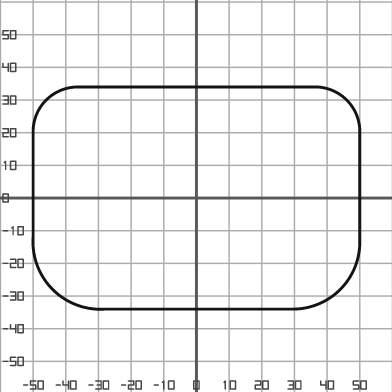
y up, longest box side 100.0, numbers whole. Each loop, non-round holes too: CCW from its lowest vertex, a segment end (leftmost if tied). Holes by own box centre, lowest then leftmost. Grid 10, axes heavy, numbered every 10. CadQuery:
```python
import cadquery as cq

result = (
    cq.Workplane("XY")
    .moveTo(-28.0, -34.0)
    .lineTo(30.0, -34.0)
    .threePointArc((44.0, -28.0), (50.0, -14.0))
    .lineTo(50.0, 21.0)
    .threePointArc((46.0, 30.0), (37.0, 34.0))
    .lineTo(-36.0, 34.0)
    .threePointArc((-46.0, 30.0), (-50.0, 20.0))
    .lineTo(-50.0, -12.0)
    .threePointArc((-44.0, -28.0), (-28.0, -34.0))
    .close()
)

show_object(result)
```